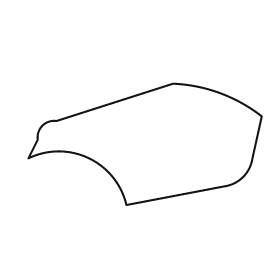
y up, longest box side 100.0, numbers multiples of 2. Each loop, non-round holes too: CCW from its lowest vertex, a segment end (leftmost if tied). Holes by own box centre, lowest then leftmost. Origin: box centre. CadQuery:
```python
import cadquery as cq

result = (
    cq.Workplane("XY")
    .moveTo(-8.0, -26.0)
    .lineTo(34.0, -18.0)
    .threePointArc((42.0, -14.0), (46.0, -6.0))
    .lineTo(50.0, 12.0)
    .threePointArc((32.0, 22.0), (12.0, 26.0))
    .lineTo(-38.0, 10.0)
    .threePointArc((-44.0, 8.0), (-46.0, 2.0))
    .lineTo(-50.0, -6.0)
    .threePointArc((-24.0, -6.0), (-8.0, -26.0))
    .close()
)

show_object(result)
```